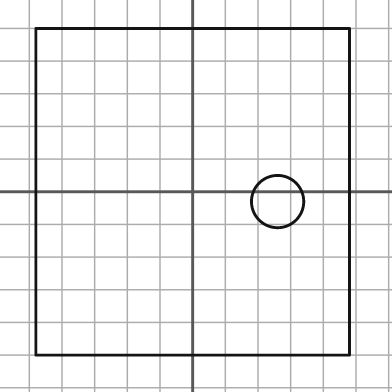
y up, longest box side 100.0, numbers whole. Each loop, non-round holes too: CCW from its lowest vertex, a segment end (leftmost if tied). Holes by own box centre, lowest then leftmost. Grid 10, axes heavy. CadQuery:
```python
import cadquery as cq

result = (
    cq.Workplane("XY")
    .moveTo(-48.0, -50.0)
    .lineTo(48.0, -50.0)
    .lineTo(48.0, 50.0)
    .lineTo(-48.0, 50.0)
    .close()
    .moveTo(26.0, -3.0)
    .circle(8.0)
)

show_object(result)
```